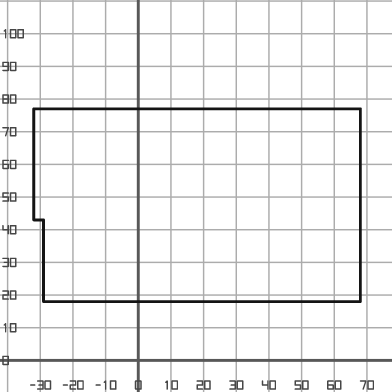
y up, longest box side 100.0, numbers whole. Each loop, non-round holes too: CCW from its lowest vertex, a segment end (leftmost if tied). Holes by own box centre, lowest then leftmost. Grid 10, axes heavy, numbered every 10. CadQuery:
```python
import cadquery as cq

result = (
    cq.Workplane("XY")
    .moveTo(-29.0, 18.0)
    .lineTo(68.0, 18.0)
    .lineTo(68.0, 77.0)
    .lineTo(-32.0, 77.0)
    .lineTo(-32.0, 43.0)
    .lineTo(-29.0, 43.0)
    .close()
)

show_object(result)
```